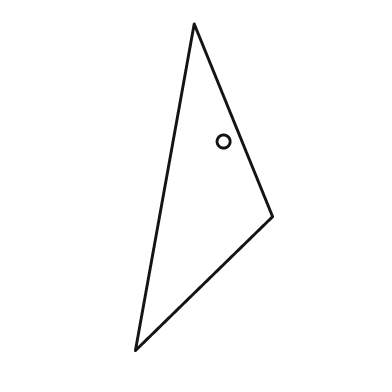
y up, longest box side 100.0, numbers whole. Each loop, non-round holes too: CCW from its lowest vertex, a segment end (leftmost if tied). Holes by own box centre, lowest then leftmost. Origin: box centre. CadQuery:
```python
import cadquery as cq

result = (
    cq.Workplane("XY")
    .moveTo(-21.0, -50.0)
    .lineTo(21.0, -9.0)
    .lineTo(-3.0, 50.0)
    .close()
    .moveTo(6.0, 14.0)
    .circle(2.0)
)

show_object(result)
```